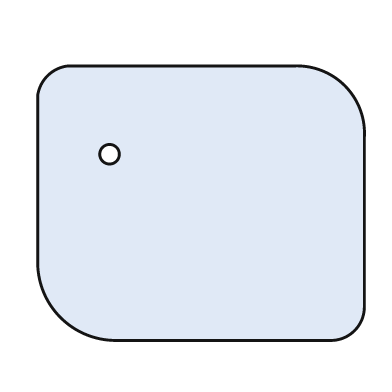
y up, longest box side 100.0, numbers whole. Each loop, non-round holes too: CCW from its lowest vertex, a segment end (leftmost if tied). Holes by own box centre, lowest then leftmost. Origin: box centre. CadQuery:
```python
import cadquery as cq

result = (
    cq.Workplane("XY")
    .moveTo(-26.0, -42.0)
    .lineTo(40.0, -42.0)
    .threePointArc((47.0, -39.0), (50.0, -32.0))
    .lineTo(50.0, 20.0)
    .threePointArc((44.0, 36.0), (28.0, 42.0))
    .lineTo(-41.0, 42.0)
    .threePointArc((-47.0, 39.0), (-50.0, 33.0))
    .lineTo(-50.0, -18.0)
    .threePointArc((-43.0, -35.0), (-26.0, -42.0))
    .close()
    .moveTo(-28.0, 15.0)
    .circle(3.0)
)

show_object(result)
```